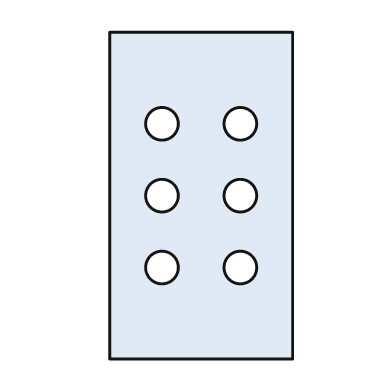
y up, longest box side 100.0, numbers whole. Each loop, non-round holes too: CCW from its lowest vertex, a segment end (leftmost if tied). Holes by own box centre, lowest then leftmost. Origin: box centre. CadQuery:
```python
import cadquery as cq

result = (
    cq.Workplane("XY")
    .moveTo(-28.0, -50.0)
    .lineTo(28.0, -50.0)
    .lineTo(28.0, 50.0)
    .lineTo(-28.0, 50.0)
    .close()
    .moveTo(-12.0, -22.0)
    .circle(5.0)
    .moveTo(12.0, -22.0)
    .circle(5.0)
    .moveTo(-12.0, 0.0)
    .circle(5.0)
    .moveTo(12.0, 0.0)
    .circle(5.0)
    .moveTo(-12.0, 22.0)
    .circle(5.0)
    .moveTo(12.0, 22.0)
    .circle(5.0)
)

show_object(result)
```